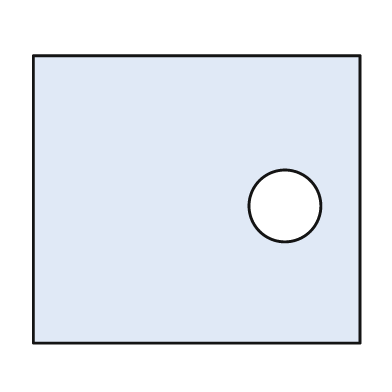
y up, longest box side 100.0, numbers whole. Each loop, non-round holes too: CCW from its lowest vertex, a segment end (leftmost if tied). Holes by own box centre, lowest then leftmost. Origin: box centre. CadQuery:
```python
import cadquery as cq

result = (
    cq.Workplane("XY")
    .moveTo(-50.0, -44.0)
    .lineTo(50.0, -44.0)
    .lineTo(50.0, 44.0)
    .lineTo(-50.0, 44.0)
    .close()
    .moveTo(27.0, -2.0)
    .circle(11.0)
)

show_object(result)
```